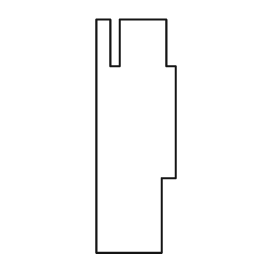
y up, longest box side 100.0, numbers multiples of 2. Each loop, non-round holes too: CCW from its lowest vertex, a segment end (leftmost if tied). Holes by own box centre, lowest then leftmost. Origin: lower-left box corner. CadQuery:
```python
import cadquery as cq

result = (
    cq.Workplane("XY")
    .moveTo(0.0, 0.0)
    .lineTo(28.0, 0.0)
    .lineTo(28.0, 32.0)
    .lineTo(34.0, 32.0)
    .lineTo(34.0, 80.0)
    .lineTo(30.0, 80.0)
    .lineTo(30.0, 100.0)
    .lineTo(10.0, 100.0)
    .lineTo(10.0, 80.0)
    .lineTo(6.0, 80.0)
    .lineTo(6.0, 100.0)
    .lineTo(0.0, 100.0)
    .close()
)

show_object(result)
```